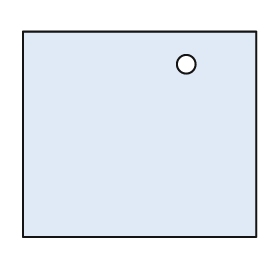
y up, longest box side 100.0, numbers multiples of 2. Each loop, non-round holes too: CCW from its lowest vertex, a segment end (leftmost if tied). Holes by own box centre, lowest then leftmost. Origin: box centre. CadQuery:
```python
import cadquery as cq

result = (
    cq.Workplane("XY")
    .moveTo(-50.0, -44.0)
    .lineTo(50.0, -44.0)
    .lineTo(50.0, 44.0)
    .lineTo(-50.0, 44.0)
    .close()
    .moveTo(20.0, 30.0)
    .circle(4.0)
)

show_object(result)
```